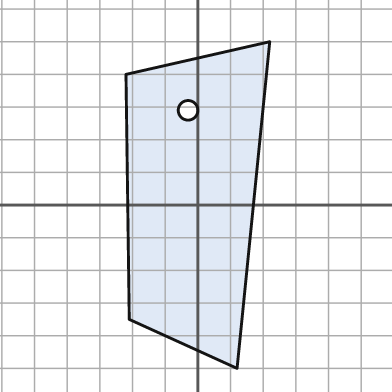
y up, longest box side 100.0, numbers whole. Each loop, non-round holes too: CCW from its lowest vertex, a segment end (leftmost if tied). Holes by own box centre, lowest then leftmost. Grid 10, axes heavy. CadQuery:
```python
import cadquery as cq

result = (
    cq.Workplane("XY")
    .moveTo(12.0, -50.0)
    .lineTo(22.0, 50.0)
    .lineTo(-22.0, 40.0)
    .lineTo(-21.0, -35.0)
    .close()
    .moveTo(-3.0, 29.0)
    .circle(3.0)
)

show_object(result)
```